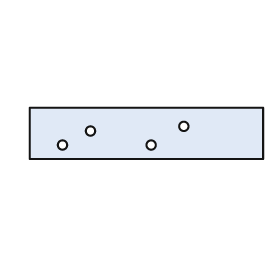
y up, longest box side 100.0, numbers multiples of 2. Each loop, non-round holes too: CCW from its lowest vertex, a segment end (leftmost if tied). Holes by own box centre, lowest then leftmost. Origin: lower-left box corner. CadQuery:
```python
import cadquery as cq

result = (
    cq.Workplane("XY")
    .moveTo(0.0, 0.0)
    .lineTo(100.0, 0.0)
    .lineTo(100.0, 22.0)
    .lineTo(0.0, 22.0)
    .close()
    .moveTo(14.0, 6.0)
    .circle(2.0)
    .moveTo(52.0, 6.0)
    .circle(2.0)
    .moveTo(26.0, 12.0)
    .circle(2.0)
    .moveTo(66.0, 14.0)
    .circle(2.0)
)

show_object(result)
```